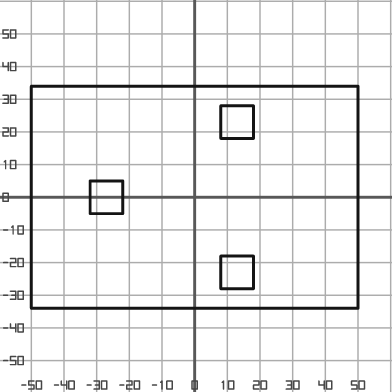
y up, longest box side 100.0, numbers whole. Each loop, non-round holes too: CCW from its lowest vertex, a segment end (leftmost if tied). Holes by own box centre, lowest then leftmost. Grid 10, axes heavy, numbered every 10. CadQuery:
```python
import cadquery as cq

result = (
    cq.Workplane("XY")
    .moveTo(-50.0, -34.0)
    .lineTo(50.0, -34.0)
    .lineTo(50.0, 34.0)
    .lineTo(-50.0, 34.0)
    .close()
    .moveTo(8.0, -28.0)
    .lineTo(18.0, -28.0)
    .lineTo(18.0, -18.0)
    .lineTo(8.0, -18.0)
    .close()
    .moveTo(-32.0, -5.0)
    .lineTo(-22.0, -5.0)
    .lineTo(-22.0, 5.0)
    .lineTo(-32.0, 5.0)
    .close()
    .moveTo(8.0, 18.0)
    .lineTo(18.0, 18.0)
    .lineTo(18.0, 28.0)
    .lineTo(8.0, 28.0)
    .close()
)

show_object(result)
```